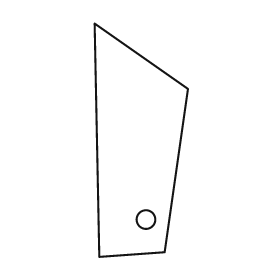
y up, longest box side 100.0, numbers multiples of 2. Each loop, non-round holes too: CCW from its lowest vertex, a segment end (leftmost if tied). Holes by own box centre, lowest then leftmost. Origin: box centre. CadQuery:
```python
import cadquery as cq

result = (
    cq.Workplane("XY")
    .moveTo(-18.0, -50.0)
    .lineTo(10.0, -48.0)
    .lineTo(20.0, 22.0)
    .lineTo(-20.0, 50.0)
    .close()
    .moveTo(2.0, -34.0)
    .circle(4.0)
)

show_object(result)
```